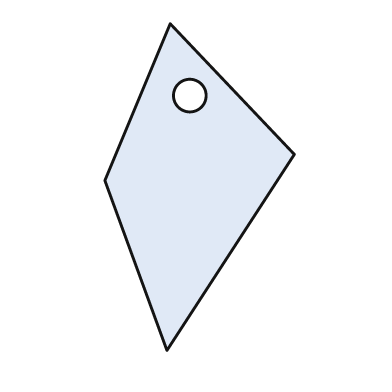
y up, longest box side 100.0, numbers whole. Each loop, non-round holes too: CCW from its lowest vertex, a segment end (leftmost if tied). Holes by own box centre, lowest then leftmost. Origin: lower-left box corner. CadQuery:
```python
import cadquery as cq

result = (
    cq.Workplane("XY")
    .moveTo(19.0, 0.0)
    .lineTo(58.0, 60.0)
    .lineTo(20.0, 100.0)
    .lineTo(0.0, 52.0)
    .close()
    .moveTo(26.0, 78.0)
    .circle(5.0)
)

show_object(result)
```